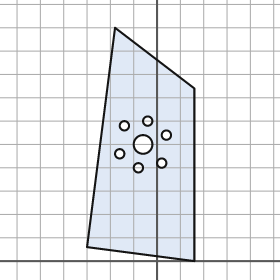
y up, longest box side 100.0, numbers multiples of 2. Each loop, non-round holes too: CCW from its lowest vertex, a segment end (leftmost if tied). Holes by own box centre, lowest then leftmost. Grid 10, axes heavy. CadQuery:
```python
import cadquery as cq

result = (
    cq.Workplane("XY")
    .moveTo(16.0, 0.0)
    .lineTo(16.0, 74.0)
    .lineTo(-18.0, 100.0)
    .lineTo(-30.0, 6.0)
    .close()
    .moveTo(-8.0, 40.0)
    .circle(2.0)
    .moveTo(2.0, 42.0)
    .circle(2.0)
    .moveTo(-16.0, 46.0)
    .circle(2.0)
    .moveTo(-6.0, 50.0)
    .circle(4.0)
    .moveTo(4.0, 54.0)
    .circle(2.0)
    .moveTo(-14.0, 58.0)
    .circle(2.0)
    .moveTo(-4.0, 60.0)
    .circle(2.0)
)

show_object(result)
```